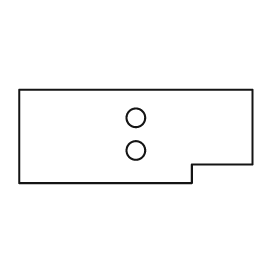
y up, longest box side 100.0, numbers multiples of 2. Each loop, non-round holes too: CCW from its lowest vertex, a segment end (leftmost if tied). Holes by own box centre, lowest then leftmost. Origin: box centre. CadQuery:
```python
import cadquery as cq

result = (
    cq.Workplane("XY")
    .moveTo(-50.0, -20.0)
    .lineTo(24.0, -20.0)
    .lineTo(24.0, -12.0)
    .lineTo(50.0, -12.0)
    .lineTo(50.0, 20.0)
    .lineTo(-50.0, 20.0)
    .close()
    .moveTo(0.0, -6.0)
    .circle(4.0)
    .moveTo(0.0, 8.0)
    .circle(4.0)
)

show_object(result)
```